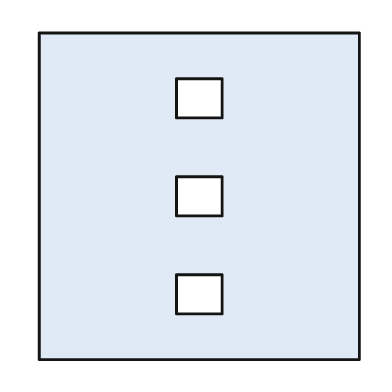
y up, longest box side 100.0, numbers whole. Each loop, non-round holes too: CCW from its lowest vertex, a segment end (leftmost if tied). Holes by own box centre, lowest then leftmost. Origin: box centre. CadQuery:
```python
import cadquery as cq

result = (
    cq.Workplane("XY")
    .moveTo(-49.0, -50.0)
    .lineTo(49.0, -50.0)
    .lineTo(49.0, 50.0)
    .lineTo(-49.0, 50.0)
    .close()
    .moveTo(-7.0, -36.0)
    .lineTo(7.0, -36.0)
    .lineTo(7.0, -24.0)
    .lineTo(-7.0, -24.0)
    .close()
    .moveTo(-7.0, -6.0)
    .lineTo(7.0, -6.0)
    .lineTo(7.0, 6.0)
    .lineTo(-7.0, 6.0)
    .close()
    .moveTo(-7.0, 24.0)
    .lineTo(7.0, 24.0)
    .lineTo(7.0, 36.0)
    .lineTo(-7.0, 36.0)
    .close()
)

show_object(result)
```